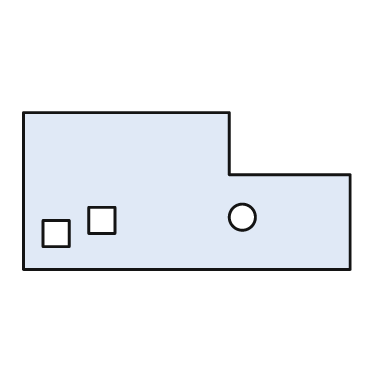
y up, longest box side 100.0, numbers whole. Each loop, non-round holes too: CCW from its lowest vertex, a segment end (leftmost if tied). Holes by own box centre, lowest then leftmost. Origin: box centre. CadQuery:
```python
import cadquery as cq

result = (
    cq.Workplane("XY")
    .moveTo(-50.0, -24.0)
    .lineTo(50.0, -24.0)
    .lineTo(50.0, 5.0)
    .lineTo(13.0, 5.0)
    .lineTo(13.0, 24.0)
    .lineTo(-50.0, 24.0)
    .close()
    .moveTo(-44.0, -17.0)
    .lineTo(-36.0, -17.0)
    .lineTo(-36.0, -9.0)
    .lineTo(-44.0, -9.0)
    .close()
    .moveTo(-30.0, -13.0)
    .lineTo(-22.0, -13.0)
    .lineTo(-22.0, -5.0)
    .lineTo(-30.0, -5.0)
    .close()
    .moveTo(17.0, -8.0)
    .circle(4.0)
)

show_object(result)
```